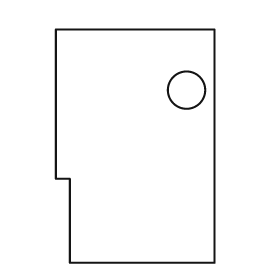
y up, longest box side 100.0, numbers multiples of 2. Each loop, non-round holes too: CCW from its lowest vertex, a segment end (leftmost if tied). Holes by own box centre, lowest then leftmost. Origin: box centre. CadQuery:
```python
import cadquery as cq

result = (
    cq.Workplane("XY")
    .moveTo(-28.0, -50.0)
    .lineTo(34.0, -50.0)
    .lineTo(34.0, 50.0)
    .lineTo(-34.0, 50.0)
    .lineTo(-34.0, -14.0)
    .lineTo(-28.0, -14.0)
    .close()
    .moveTo(22.0, 24.0)
    .circle(8.0)
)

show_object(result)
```